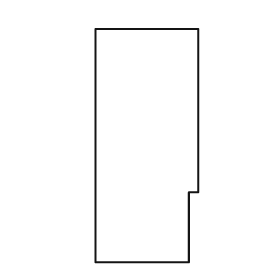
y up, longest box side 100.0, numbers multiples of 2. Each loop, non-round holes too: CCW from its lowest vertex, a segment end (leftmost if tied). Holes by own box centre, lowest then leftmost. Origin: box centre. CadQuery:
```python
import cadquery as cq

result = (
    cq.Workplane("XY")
    .moveTo(-22.0, -50.0)
    .lineTo(18.0, -50.0)
    .lineTo(18.0, -20.0)
    .lineTo(22.0, -20.0)
    .lineTo(22.0, 50.0)
    .lineTo(-22.0, 50.0)
    .close()
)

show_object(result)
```